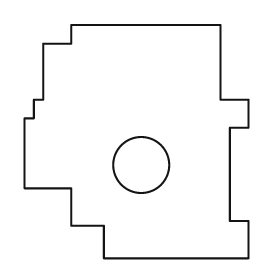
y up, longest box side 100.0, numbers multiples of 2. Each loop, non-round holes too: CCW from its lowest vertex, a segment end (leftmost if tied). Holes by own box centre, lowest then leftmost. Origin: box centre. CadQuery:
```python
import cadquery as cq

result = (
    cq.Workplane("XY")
    .moveTo(-14.0, -50.0)
    .lineTo(48.0, -50.0)
    .lineTo(48.0, -34.0)
    .lineTo(40.0, -34.0)
    .lineTo(40.0, 6.0)
    .lineTo(48.0, 6.0)
    .lineTo(48.0, 18.0)
    .lineTo(36.0, 18.0)
    .lineTo(36.0, 50.0)
    .lineTo(-28.0, 50.0)
    .lineTo(-28.0, 42.0)
    .lineTo(-40.0, 42.0)
    .lineTo(-40.0, 18.0)
    .lineTo(-44.0, 18.0)
    .lineTo(-44.0, 10.0)
    .lineTo(-48.0, 10.0)
    .lineTo(-48.0, -20.0)
    .lineTo(-28.0, -20.0)
    .lineTo(-28.0, -36.0)
    .lineTo(-14.0, -36.0)
    .close()
    .moveTo(2.0, -10.0)
    .circle(12.0)
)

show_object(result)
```